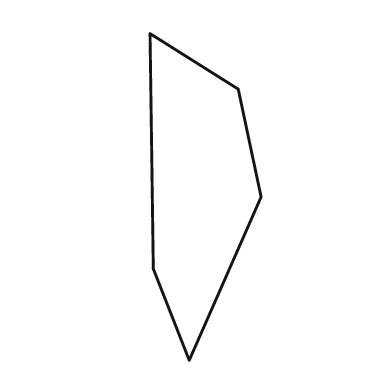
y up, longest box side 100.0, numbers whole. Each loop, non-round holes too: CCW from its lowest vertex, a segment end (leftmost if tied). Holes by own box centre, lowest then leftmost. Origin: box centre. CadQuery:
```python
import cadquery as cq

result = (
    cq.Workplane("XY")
    .moveTo(-5.0, -50.0)
    .lineTo(17.0, 0.0)
    .lineTo(10.0, 33.0)
    .lineTo(-17.0, 50.0)
    .lineTo(-16.0, -22.0)
    .close()
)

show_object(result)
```